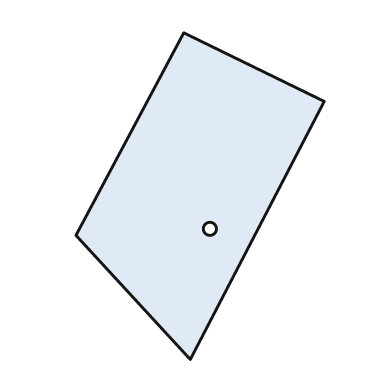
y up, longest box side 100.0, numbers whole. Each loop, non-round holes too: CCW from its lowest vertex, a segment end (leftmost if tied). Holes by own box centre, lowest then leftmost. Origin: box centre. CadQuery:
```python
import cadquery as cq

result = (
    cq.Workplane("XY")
    .moveTo(-3.0, -50.0)
    .lineTo(38.0, 29.0)
    .lineTo(-5.0, 50.0)
    .lineTo(-38.0, -12.0)
    .close()
    .moveTo(3.0, -10.0)
    .circle(2.0)
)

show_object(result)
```